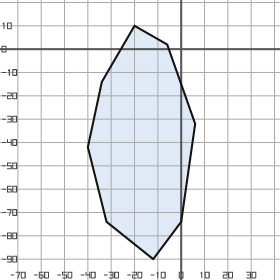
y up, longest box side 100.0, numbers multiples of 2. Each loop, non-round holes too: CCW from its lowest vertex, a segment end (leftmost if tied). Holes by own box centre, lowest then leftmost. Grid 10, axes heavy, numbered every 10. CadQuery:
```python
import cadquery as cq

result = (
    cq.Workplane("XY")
    .moveTo(-12.0, -90.0)
    .lineTo(0.0, -74.0)
    .lineTo(6.0, -32.0)
    .lineTo(-6.0, 2.0)
    .lineTo(-20.0, 10.0)
    .lineTo(-34.0, -14.0)
    .lineTo(-40.0, -42.0)
    .lineTo(-32.0, -74.0)
    .close()
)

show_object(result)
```